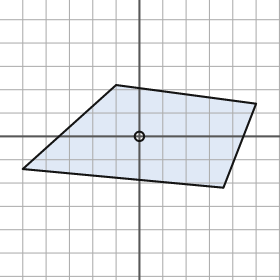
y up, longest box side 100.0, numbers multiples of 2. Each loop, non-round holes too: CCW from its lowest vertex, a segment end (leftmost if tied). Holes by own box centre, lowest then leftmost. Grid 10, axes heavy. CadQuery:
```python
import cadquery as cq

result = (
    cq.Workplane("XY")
    .moveTo(36.0, -22.0)
    .lineTo(50.0, 14.0)
    .lineTo(-10.0, 22.0)
    .lineTo(-50.0, -14.0)
    .close()
    .moveTo(0.0, 0.0)
    .circle(2.0)
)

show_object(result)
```